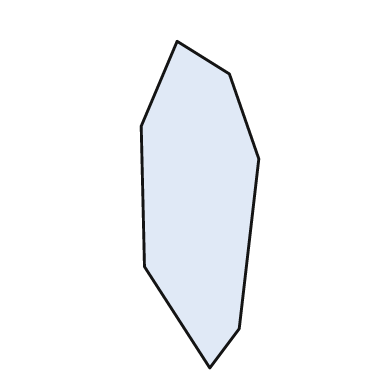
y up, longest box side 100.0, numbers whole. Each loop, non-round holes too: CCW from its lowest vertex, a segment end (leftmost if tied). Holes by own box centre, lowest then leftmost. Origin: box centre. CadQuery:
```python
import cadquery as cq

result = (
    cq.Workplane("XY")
    .moveTo(3.0, -50.0)
    .lineTo(12.0, -38.0)
    .lineTo(18.0, 14.0)
    .lineTo(9.0, 40.0)
    .lineTo(-7.0, 50.0)
    .lineTo(-18.0, 24.0)
    .lineTo(-17.0, -19.0)
    .close()
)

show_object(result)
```